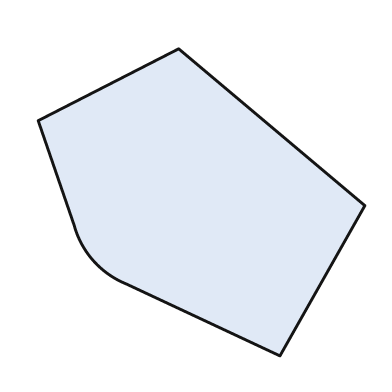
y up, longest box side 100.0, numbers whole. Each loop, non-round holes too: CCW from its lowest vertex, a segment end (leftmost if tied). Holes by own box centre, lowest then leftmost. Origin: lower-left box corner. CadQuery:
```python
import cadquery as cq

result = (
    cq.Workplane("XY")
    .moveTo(74.0, 0.0)
    .lineTo(100.0, 46.0)
    .lineTo(43.0, 94.0)
    .lineTo(0.0, 72.0)
    .lineTo(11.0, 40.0)
    .threePointArc((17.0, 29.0), (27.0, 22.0))
    .close()
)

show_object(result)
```